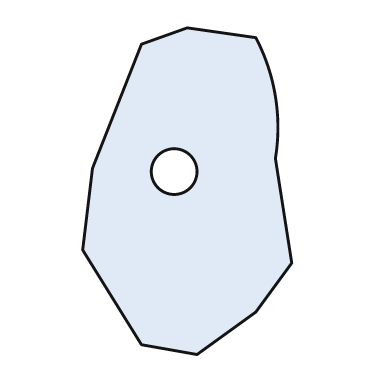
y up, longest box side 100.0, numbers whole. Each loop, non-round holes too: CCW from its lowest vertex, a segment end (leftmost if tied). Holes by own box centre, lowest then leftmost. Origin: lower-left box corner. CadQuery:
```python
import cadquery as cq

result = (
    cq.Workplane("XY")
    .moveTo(35.0, 0.0)
    .lineTo(53.0, 13.0)
    .lineTo(64.0, 28.0)
    .lineTo(59.0, 60.0)
    .threePointArc((59.0, 79.0), (53.0, 97.0))
    .lineTo(32.0, 100.0)
    .lineTo(18.0, 95.0)
    .lineTo(3.0, 57.0)
    .lineTo(0.0, 32.0)
    .lineTo(18.0, 3.0)
    .close()
    .moveTo(28.0, 56.0)
    .circle(7.0)
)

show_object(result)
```